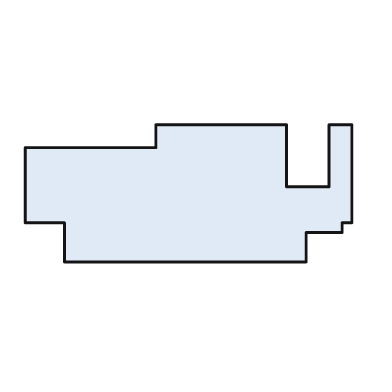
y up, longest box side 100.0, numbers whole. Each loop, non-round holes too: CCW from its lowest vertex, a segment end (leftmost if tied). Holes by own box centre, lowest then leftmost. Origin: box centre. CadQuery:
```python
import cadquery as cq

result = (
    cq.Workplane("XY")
    .moveTo(-38.0, -21.0)
    .lineTo(36.0, -21.0)
    .lineTo(36.0, -12.0)
    .lineTo(47.0, -12.0)
    .lineTo(47.0, -9.0)
    .lineTo(50.0, -9.0)
    .lineTo(50.0, 21.0)
    .lineTo(43.0, 21.0)
    .lineTo(43.0, 2.0)
    .lineTo(30.0, 2.0)
    .lineTo(30.0, 21.0)
    .lineTo(-10.0, 21.0)
    .lineTo(-10.0, 14.0)
    .lineTo(-50.0, 14.0)
    .lineTo(-50.0, -9.0)
    .lineTo(-38.0, -9.0)
    .close()
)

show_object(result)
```